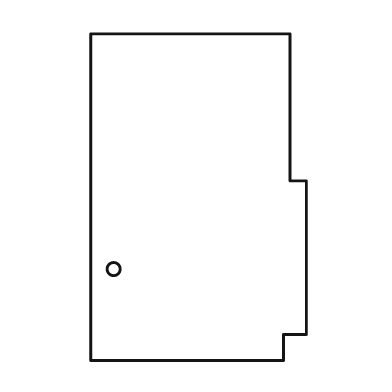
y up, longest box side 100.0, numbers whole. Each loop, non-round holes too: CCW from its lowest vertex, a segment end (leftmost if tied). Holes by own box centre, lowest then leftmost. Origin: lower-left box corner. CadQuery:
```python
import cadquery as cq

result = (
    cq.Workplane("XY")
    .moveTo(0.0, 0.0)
    .lineTo(59.0, 0.0)
    .lineTo(59.0, 8.0)
    .lineTo(66.0, 8.0)
    .lineTo(66.0, 55.0)
    .lineTo(61.0, 55.0)
    .lineTo(61.0, 100.0)
    .lineTo(0.0, 100.0)
    .close()
    .moveTo(7.0, 28.0)
    .circle(2.0)
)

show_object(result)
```